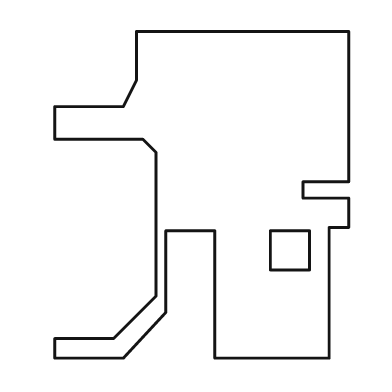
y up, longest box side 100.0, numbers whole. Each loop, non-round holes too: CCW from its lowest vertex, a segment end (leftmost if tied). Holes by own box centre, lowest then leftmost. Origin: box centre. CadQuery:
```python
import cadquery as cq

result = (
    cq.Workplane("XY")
    .moveTo(-45.0, -50.0)
    .lineTo(-24.0, -50.0)
    .lineTo(-11.0, -36.0)
    .lineTo(-11.0, -11.0)
    .lineTo(4.0, -11.0)
    .lineTo(4.0, -50.0)
    .lineTo(39.0, -50.0)
    .lineTo(39.0, -10.0)
    .lineTo(45.0, -10.0)
    .lineTo(45.0, -1.0)
    .lineTo(31.0, -1.0)
    .lineTo(31.0, 4.0)
    .lineTo(45.0, 4.0)
    .lineTo(45.0, 50.0)
    .lineTo(-20.0, 50.0)
    .lineTo(-20.0, 35.0)
    .lineTo(-24.0, 27.0)
    .lineTo(-45.0, 27.0)
    .lineTo(-45.0, 17.0)
    .lineTo(-18.0, 17.0)
    .lineTo(-14.0, 13.0)
    .lineTo(-14.0, -31.0)
    .lineTo(-27.0, -44.0)
    .lineTo(-45.0, -44.0)
    .close()
    .moveTo(21.0, -23.0)
    .lineTo(33.0, -23.0)
    .lineTo(33.0, -11.0)
    .lineTo(21.0, -11.0)
    .close()
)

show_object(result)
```